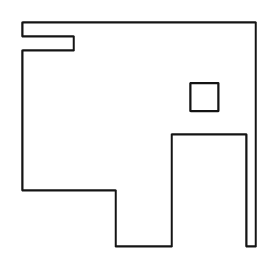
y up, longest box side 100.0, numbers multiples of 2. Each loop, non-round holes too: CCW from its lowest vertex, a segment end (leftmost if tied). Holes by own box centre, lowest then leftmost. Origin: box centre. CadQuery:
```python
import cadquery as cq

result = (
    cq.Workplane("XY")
    .moveTo(-10.0, -48.0)
    .lineTo(14.0, -48.0)
    .lineTo(14.0, 0.0)
    .lineTo(46.0, 0.0)
    .lineTo(46.0, -48.0)
    .lineTo(50.0, -48.0)
    .lineTo(50.0, 48.0)
    .lineTo(-50.0, 48.0)
    .lineTo(-50.0, 42.0)
    .lineTo(-28.0, 42.0)
    .lineTo(-28.0, 36.0)
    .lineTo(-50.0, 36.0)
    .lineTo(-50.0, -24.0)
    .lineTo(-10.0, -24.0)
    .close()
    .moveTo(22.0, 10.0)
    .lineTo(34.0, 10.0)
    .lineTo(34.0, 22.0)
    .lineTo(22.0, 22.0)
    .close()
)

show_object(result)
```